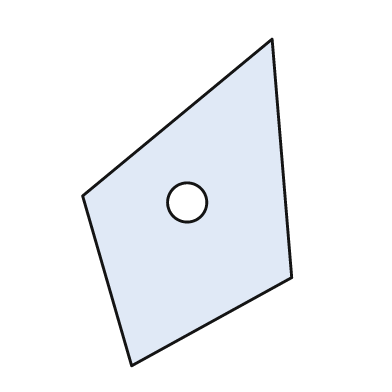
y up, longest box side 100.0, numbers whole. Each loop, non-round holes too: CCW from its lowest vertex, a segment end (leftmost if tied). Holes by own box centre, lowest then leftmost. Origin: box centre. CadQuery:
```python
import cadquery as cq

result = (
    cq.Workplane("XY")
    .moveTo(-17.0, -50.0)
    .lineTo(32.0, -23.0)
    .lineTo(26.0, 50.0)
    .lineTo(-32.0, 2.0)
    .close()
    .moveTo(0.0, 0.0)
    .circle(6.0)
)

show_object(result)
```